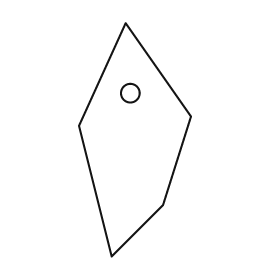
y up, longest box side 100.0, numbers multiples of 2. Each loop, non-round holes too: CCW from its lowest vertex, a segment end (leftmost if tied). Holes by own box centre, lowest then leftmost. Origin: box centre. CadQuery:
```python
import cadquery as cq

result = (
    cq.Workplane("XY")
    .moveTo(-10.0, -50.0)
    .lineTo(12.0, -28.0)
    .lineTo(24.0, 10.0)
    .lineTo(-4.0, 50.0)
    .lineTo(-24.0, 6.0)
    .close()
    .moveTo(-2.0, 20.0)
    .circle(4.0)
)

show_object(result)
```